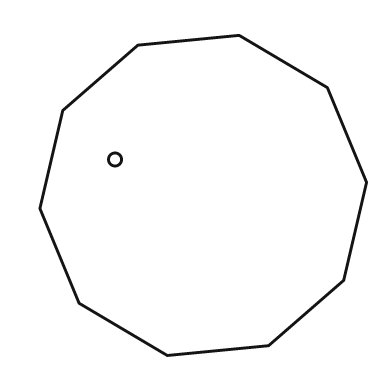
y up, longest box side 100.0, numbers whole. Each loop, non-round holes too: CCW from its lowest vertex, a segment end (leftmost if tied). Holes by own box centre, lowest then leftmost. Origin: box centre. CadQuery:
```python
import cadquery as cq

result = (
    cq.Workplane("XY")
    .moveTo(-11.0, -49.0)
    .lineTo(20.0, -46.0)
    .lineTo(43.0, -26.0)
    .lineTo(50.0, 4.0)
    .lineTo(38.0, 33.0)
    .lineTo(11.0, 49.0)
    .lineTo(-20.0, 46.0)
    .lineTo(-43.0, 26.0)
    .lineTo(-50.0, -4.0)
    .lineTo(-38.0, -33.0)
    .close()
    .moveTo(-27.0, 11.0)
    .circle(2.0)
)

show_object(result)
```